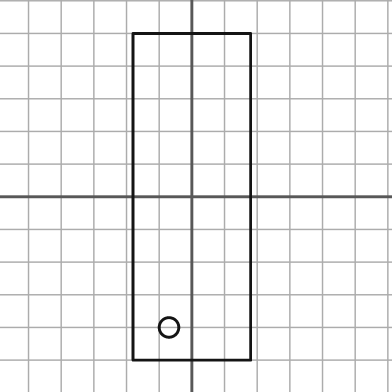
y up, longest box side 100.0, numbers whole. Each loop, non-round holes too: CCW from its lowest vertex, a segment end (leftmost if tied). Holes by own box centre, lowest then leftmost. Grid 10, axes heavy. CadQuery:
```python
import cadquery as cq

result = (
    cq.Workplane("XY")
    .moveTo(-18.0, -50.0)
    .lineTo(18.0, -50.0)
    .lineTo(18.0, 50.0)
    .lineTo(-18.0, 50.0)
    .close()
    .moveTo(-7.0, -40.0)
    .circle(3.0)
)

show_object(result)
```